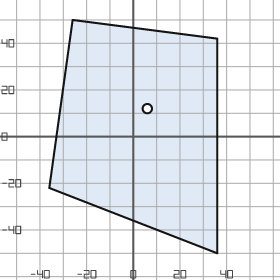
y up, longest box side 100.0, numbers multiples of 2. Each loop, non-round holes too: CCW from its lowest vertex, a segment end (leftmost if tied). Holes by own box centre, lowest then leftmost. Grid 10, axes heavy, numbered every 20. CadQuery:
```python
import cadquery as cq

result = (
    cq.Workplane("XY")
    .moveTo(36.0, -50.0)
    .lineTo(36.0, 42.0)
    .lineTo(-26.0, 50.0)
    .lineTo(-36.0, -22.0)
    .close()
    .moveTo(6.0, 12.0)
    .circle(2.0)
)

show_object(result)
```